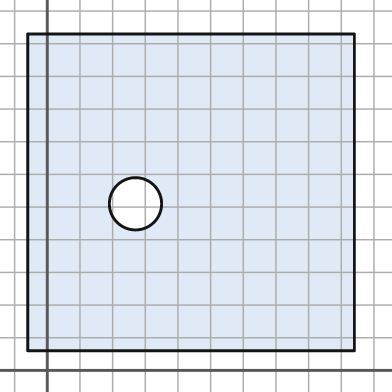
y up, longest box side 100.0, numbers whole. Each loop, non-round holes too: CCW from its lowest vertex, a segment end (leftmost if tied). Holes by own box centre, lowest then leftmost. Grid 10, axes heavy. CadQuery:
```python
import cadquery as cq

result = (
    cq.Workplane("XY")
    .moveTo(-6.0, 6.0)
    .lineTo(94.0, 6.0)
    .lineTo(94.0, 103.0)
    .lineTo(-6.0, 103.0)
    .close()
    .moveTo(27.0, 51.0)
    .circle(8.0)
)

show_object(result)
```